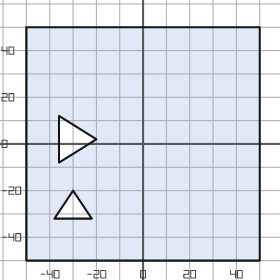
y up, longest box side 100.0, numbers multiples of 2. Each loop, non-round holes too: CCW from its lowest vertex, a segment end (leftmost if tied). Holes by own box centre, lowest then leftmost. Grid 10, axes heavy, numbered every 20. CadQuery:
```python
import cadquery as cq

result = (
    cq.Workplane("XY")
    .moveTo(-50.0, -50.0)
    .lineTo(50.0, -50.0)
    .lineTo(50.0, 50.0)
    .lineTo(-50.0, 50.0)
    .close()
    .moveTo(-38.0, -32.0)
    .lineTo(-22.0, -32.0)
    .lineTo(-30.0, -20.0)
    .close()
    .moveTo(-36.0, -8.0)
    .lineTo(-20.0, 2.0)
    .lineTo(-36.0, 12.0)
    .close()
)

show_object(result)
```